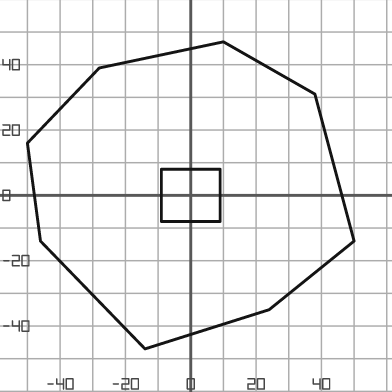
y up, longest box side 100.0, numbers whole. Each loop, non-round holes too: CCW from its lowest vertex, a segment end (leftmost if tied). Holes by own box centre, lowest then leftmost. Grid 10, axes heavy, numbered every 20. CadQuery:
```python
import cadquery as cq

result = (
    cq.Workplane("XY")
    .moveTo(-14.0, -47.0)
    .lineTo(24.0, -35.0)
    .lineTo(50.0, -14.0)
    .lineTo(38.0, 31.0)
    .lineTo(10.0, 47.0)
    .lineTo(-28.0, 39.0)
    .lineTo(-50.0, 16.0)
    .lineTo(-46.0, -14.0)
    .close()
    .moveTo(-9.0, -8.0)
    .lineTo(9.0, -8.0)
    .lineTo(9.0, 8.0)
    .lineTo(-9.0, 8.0)
    .close()
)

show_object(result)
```